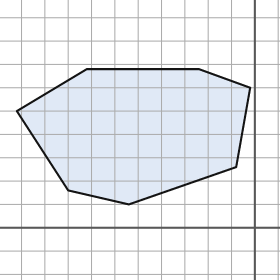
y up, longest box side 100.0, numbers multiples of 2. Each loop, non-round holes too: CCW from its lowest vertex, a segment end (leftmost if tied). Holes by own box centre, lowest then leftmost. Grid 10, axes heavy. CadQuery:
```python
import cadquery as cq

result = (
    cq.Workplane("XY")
    .moveTo(-54.0, 10.0)
    .lineTo(-8.0, 26.0)
    .lineTo(-2.0, 60.0)
    .lineTo(-24.0, 68.0)
    .lineTo(-72.0, 68.0)
    .lineTo(-102.0, 50.0)
    .lineTo(-80.0, 16.0)
    .close()
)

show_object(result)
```